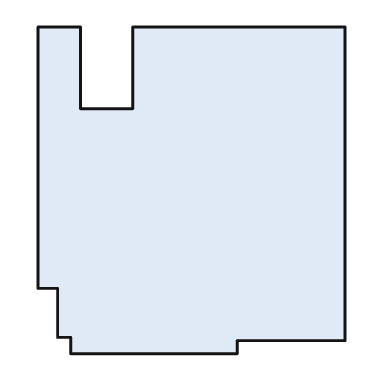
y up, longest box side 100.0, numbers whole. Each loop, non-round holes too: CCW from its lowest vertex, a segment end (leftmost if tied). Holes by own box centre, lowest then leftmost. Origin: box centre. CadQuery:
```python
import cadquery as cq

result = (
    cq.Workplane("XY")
    .moveTo(-37.0, -50.0)
    .lineTo(14.0, -50.0)
    .lineTo(14.0, -46.0)
    .lineTo(47.0, -46.0)
    .lineTo(47.0, 50.0)
    .lineTo(-18.0, 50.0)
    .lineTo(-18.0, 25.0)
    .lineTo(-34.0, 25.0)
    .lineTo(-34.0, 50.0)
    .lineTo(-47.0, 50.0)
    .lineTo(-47.0, -30.0)
    .lineTo(-41.0, -30.0)
    .lineTo(-41.0, -45.0)
    .lineTo(-37.0, -45.0)
    .close()
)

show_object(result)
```